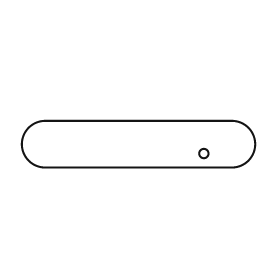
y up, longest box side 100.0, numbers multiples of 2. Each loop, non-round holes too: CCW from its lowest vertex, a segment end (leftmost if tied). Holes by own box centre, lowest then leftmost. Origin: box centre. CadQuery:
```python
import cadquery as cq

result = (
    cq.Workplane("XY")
    .moveTo(-40.0, -10.0)
    .lineTo(40.0, -10.0)
    .threePointArc((50.0, 0.0), (40.0, 10.0))
    .lineTo(-40.0, 10.0)
    .threePointArc((-50.0, 0.0), (-40.0, -10.0))
    .close()
    .moveTo(28.0, -4.0)
    .circle(2.0)
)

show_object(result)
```